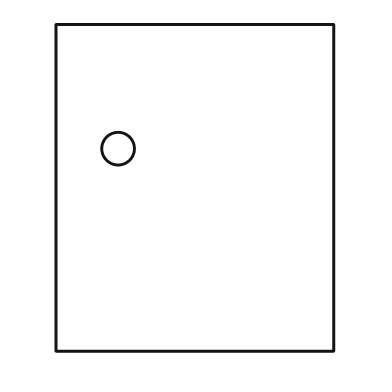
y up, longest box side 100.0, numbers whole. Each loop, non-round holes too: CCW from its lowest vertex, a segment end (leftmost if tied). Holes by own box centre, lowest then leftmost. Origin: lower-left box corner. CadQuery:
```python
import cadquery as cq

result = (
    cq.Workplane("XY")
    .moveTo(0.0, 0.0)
    .lineTo(85.0, 0.0)
    .lineTo(85.0, 100.0)
    .lineTo(0.0, 100.0)
    .close()
    .moveTo(19.0, 62.0)
    .circle(5.0)
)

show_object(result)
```